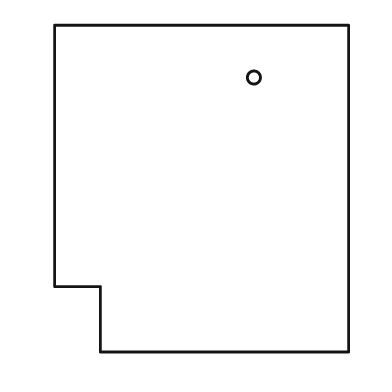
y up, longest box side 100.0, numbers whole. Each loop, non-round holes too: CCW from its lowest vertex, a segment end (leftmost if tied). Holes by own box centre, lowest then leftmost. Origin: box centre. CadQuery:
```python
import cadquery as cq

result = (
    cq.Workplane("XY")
    .moveTo(-31.0, -50.0)
    .lineTo(45.0, -50.0)
    .lineTo(45.0, 50.0)
    .lineTo(-45.0, 50.0)
    .lineTo(-45.0, -30.0)
    .lineTo(-31.0, -30.0)
    .close()
    .moveTo(16.0, 34.0)
    .circle(2.0)
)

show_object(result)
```